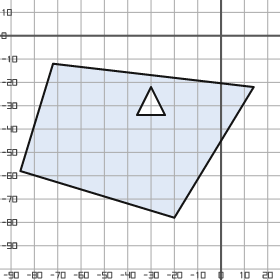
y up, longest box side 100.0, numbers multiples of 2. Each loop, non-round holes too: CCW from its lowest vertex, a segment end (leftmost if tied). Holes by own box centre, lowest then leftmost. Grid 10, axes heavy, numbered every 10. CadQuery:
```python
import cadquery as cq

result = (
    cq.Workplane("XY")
    .moveTo(-20.0, -78.0)
    .lineTo(14.0, -22.0)
    .lineTo(-72.0, -12.0)
    .lineTo(-86.0, -58.0)
    .close()
    .moveTo(-36.0, -34.0)
    .lineTo(-24.0, -34.0)
    .lineTo(-30.0, -22.0)
    .close()
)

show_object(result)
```